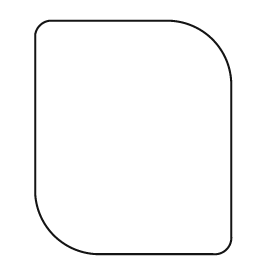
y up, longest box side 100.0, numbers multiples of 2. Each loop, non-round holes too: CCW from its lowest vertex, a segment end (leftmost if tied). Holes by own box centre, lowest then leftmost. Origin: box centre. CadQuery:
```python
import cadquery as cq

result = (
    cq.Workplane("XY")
    .moveTo(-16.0, -50.0)
    .lineTo(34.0, -50.0)
    .threePointArc((40.0, -48.0), (42.0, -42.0))
    .lineTo(42.0, 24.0)
    .threePointArc((34.0, 42.0), (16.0, 50.0))
    .lineTo(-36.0, 50.0)
    .threePointArc((-40.0, 48.0), (-42.0, 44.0))
    .lineTo(-42.0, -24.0)
    .threePointArc((-34.0, -42.0), (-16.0, -50.0))
    .close()
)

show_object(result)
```